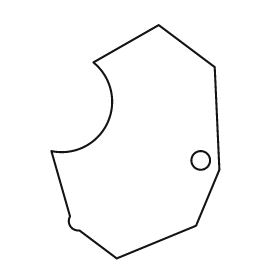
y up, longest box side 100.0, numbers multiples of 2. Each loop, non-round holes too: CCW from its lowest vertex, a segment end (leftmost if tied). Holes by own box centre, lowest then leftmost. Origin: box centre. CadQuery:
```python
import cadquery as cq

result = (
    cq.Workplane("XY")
    .moveTo(-8.0, -50.0)
    .lineTo(26.0, -36.0)
    .lineTo(36.0, -12.0)
    .lineTo(34.0, 32.0)
    .lineTo(10.0, 50.0)
    .lineTo(-18.0, 34.0)
    .threePointArc((-12.0, 8.0), (-36.0, -4.0))
    .lineTo(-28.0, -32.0)
    .threePointArc((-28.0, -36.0), (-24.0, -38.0))
    .close()
    .moveTo(28.0, -8.0)
    .circle(4.0)
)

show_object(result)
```